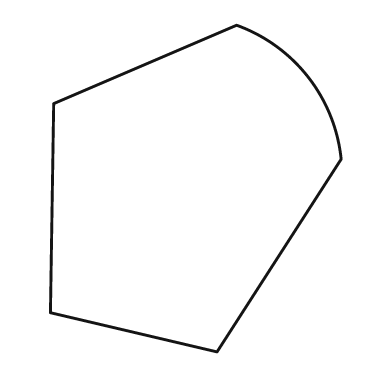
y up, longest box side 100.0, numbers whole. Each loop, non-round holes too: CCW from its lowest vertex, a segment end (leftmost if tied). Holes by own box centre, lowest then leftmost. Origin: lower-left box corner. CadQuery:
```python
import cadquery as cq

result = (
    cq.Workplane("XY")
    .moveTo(51.0, 0.0)
    .lineTo(89.0, 59.0)
    .threePointArc((79.0, 84.0), (57.0, 100.0))
    .lineTo(1.0, 76.0)
    .lineTo(0.0, 12.0)
    .close()
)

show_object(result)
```